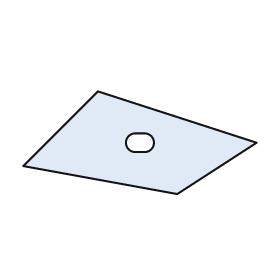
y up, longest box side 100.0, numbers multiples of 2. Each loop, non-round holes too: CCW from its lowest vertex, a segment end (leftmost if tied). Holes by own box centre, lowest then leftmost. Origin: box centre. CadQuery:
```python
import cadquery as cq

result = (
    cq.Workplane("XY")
    .moveTo(16.0, -22.0)
    .lineTo(50.0, 0.0)
    .lineTo(-18.0, 22.0)
    .lineTo(-50.0, -10.0)
    .close()
    .moveTo(-2.0, -4.0)
    .lineTo(2.0, -4.0)
    .threePointArc((6.0, 0.0), (2.0, 4.0))
    .lineTo(-2.0, 4.0)
    .threePointArc((-6.0, 0.0), (-2.0, -4.0))
    .close()
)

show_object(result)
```